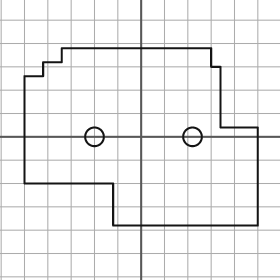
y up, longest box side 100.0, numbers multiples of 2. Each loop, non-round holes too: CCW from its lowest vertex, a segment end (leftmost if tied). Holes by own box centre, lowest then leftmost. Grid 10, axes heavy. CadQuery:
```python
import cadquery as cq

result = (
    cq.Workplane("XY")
    .moveTo(-12.0, -38.0)
    .lineTo(50.0, -38.0)
    .lineTo(50.0, 4.0)
    .lineTo(34.0, 4.0)
    .lineTo(34.0, 30.0)
    .lineTo(30.0, 30.0)
    .lineTo(30.0, 38.0)
    .lineTo(-34.0, 38.0)
    .lineTo(-34.0, 32.0)
    .lineTo(-42.0, 32.0)
    .lineTo(-42.0, 26.0)
    .lineTo(-50.0, 26.0)
    .lineTo(-50.0, -20.0)
    .lineTo(-12.0, -20.0)
    .close()
    .moveTo(-20.0, 0.0)
    .circle(4.0)
    .moveTo(22.0, 0.0)
    .circle(4.0)
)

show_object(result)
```